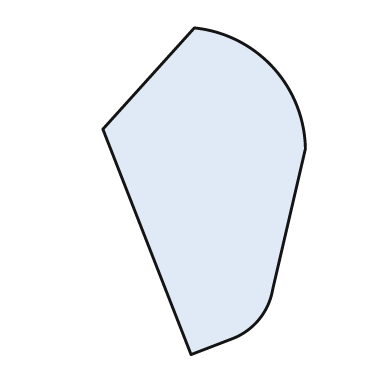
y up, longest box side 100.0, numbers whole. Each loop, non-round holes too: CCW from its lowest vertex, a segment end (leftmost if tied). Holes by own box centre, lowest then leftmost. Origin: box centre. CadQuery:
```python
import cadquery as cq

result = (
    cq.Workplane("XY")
    .moveTo(-4.0, -50.0)
    .lineTo(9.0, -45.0)
    .threePointArc((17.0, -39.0), (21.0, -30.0))
    .lineTo(31.0, 13.0)
    .threePointArc((21.0, 38.0), (-3.0, 50.0))
    .lineTo(-31.0, 19.0)
    .close()
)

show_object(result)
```